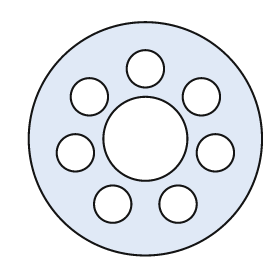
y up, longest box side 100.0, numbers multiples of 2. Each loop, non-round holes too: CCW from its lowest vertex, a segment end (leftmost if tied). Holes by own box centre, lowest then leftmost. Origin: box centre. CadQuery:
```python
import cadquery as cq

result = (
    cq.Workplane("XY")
    .moveTo(0.0, 0.0)
    .circle(50.0)
    .moveTo(-14.0, -28.0)
    .circle(8.0)
    .moveTo(14.0, -28.0)
    .circle(8.0)
    .moveTo(-30.0, -6.0)
    .circle(8.0)
    .moveTo(30.0, -6.0)
    .circle(8.0)
    .moveTo(0.0, 0.0)
    .circle(18.0)
    .moveTo(-24.0, 18.0)
    .circle(8.0)
    .moveTo(24.0, 18.0)
    .circle(8.0)
    .moveTo(0.0, 30.0)
    .circle(8.0)
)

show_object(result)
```